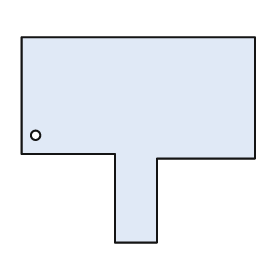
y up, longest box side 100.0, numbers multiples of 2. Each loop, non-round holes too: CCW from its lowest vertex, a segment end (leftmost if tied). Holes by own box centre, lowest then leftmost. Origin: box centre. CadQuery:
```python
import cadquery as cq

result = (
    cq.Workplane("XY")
    .moveTo(-10.0, -44.0)
    .lineTo(8.0, -44.0)
    .lineTo(8.0, -8.0)
    .lineTo(50.0, -8.0)
    .lineTo(50.0, 44.0)
    .lineTo(-50.0, 44.0)
    .lineTo(-50.0, -6.0)
    .lineTo(-10.0, -6.0)
    .close()
    .moveTo(-44.0, 2.0)
    .circle(2.0)
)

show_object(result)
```